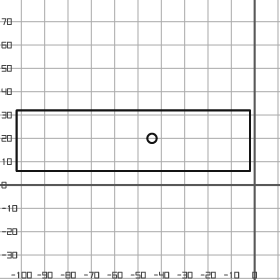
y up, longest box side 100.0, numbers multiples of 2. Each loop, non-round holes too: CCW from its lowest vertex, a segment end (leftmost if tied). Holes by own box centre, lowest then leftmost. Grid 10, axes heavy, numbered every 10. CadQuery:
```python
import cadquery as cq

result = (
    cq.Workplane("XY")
    .moveTo(-102.0, 6.0)
    .lineTo(-2.0, 6.0)
    .lineTo(-2.0, 32.0)
    .lineTo(-102.0, 32.0)
    .close()
    .moveTo(-44.0, 20.0)
    .circle(2.0)
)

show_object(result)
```